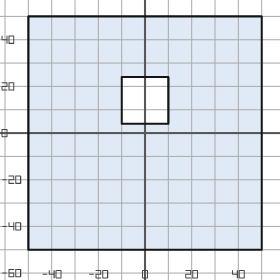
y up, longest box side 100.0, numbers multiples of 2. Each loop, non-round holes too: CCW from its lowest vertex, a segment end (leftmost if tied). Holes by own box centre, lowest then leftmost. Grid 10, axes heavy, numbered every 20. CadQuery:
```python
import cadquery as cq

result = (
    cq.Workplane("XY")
    .moveTo(-50.0, -50.0)
    .lineTo(50.0, -50.0)
    .lineTo(50.0, 50.0)
    .lineTo(-50.0, 50.0)
    .close()
    .moveTo(-10.0, 4.0)
    .lineTo(10.0, 4.0)
    .lineTo(10.0, 24.0)
    .lineTo(-10.0, 24.0)
    .close()
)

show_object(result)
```